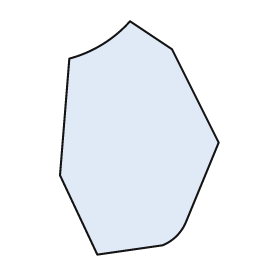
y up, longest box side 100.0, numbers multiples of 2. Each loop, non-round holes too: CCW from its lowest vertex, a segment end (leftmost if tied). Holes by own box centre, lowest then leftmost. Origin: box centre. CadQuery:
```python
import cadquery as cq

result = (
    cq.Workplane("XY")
    .moveTo(-18.0, -50.0)
    .lineTo(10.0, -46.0)
    .threePointArc((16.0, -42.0), (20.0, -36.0))
    .lineTo(34.0, -2.0)
    .lineTo(14.0, 38.0)
    .lineTo(-4.0, 50.0)
    .threePointArc((-16.0, 40.0), (-30.0, 34.0))
    .lineTo(-34.0, -16.0)
    .close()
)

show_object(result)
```